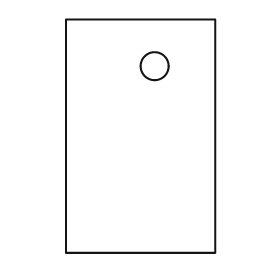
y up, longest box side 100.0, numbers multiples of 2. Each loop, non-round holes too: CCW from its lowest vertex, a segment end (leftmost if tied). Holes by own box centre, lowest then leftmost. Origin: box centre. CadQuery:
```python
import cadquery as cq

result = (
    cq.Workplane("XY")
    .moveTo(-32.0, -50.0)
    .lineTo(32.0, -50.0)
    .lineTo(32.0, 50.0)
    .lineTo(-32.0, 50.0)
    .close()
    .moveTo(6.0, 30.0)
    .circle(6.0)
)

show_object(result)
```